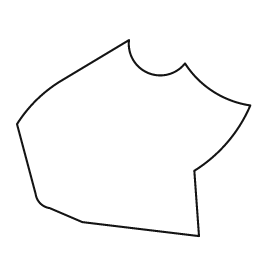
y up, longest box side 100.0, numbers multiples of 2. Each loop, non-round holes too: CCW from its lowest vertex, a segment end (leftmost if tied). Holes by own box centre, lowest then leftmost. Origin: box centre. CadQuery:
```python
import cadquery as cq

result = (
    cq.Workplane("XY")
    .moveTo(28.0, -42.0)
    .lineTo(26.0, -14.0)
    .threePointArc((40.0, -2.0), (50.0, 14.0))
    .threePointArc((34.0, 20.0), (22.0, 32.0))
    .threePointArc((6.0, 28.0), (-2.0, 42.0))
    .lineTo(-32.0, 24.0)
    .threePointArc((-42.0, 16.0), (-50.0, 6.0))
    .lineTo(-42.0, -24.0)
    .threePointArc((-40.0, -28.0), (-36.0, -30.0))
    .lineTo(-22.0, -36.0)
    .close()
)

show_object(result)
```